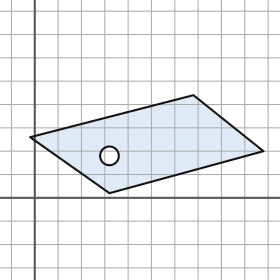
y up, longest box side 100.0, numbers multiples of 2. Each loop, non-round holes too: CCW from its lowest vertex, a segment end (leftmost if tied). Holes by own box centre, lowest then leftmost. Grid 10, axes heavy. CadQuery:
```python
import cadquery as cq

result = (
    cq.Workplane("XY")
    .moveTo(32.0, 2.0)
    .lineTo(98.0, 20.0)
    .lineTo(68.0, 44.0)
    .lineTo(-2.0, 26.0)
    .close()
    .moveTo(32.0, 18.0)
    .circle(4.0)
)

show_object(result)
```